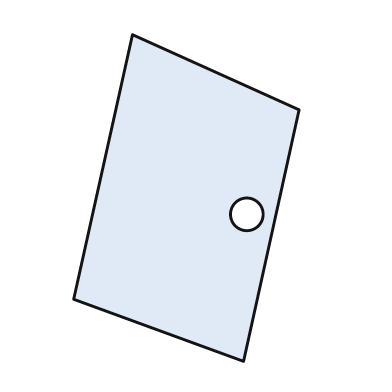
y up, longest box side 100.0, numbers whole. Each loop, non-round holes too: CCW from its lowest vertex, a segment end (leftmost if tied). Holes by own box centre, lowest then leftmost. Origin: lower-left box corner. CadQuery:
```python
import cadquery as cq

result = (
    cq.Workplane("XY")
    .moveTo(52.0, 0.0)
    .lineTo(69.0, 77.0)
    .lineTo(18.0, 100.0)
    .lineTo(0.0, 19.0)
    .close()
    .moveTo(53.0, 45.0)
    .circle(5.0)
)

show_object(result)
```